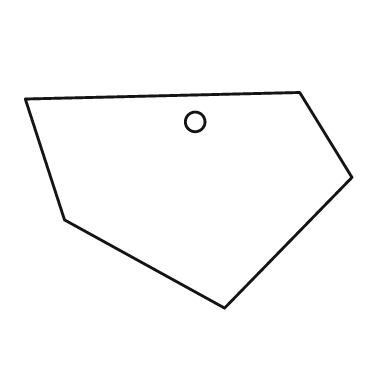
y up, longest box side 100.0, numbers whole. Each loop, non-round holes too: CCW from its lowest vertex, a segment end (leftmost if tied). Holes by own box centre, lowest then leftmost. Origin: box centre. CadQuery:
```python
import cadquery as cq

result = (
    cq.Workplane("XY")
    .moveTo(11.0, -33.0)
    .lineTo(50.0, 7.0)
    .lineTo(34.0, 33.0)
    .lineTo(-50.0, 31.0)
    .lineTo(-38.0, -6.0)
    .close()
    .moveTo(2.0, 24.0)
    .circle(3.0)
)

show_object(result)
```